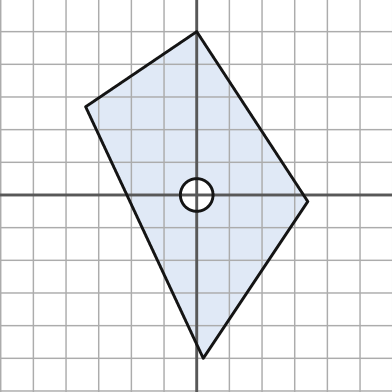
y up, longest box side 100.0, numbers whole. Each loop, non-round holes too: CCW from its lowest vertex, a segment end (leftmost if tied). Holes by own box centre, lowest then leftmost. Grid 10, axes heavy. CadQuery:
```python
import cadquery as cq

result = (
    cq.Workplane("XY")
    .moveTo(2.0, -50.0)
    .lineTo(34.0, -2.0)
    .lineTo(0.0, 50.0)
    .lineTo(-34.0, 27.0)
    .close()
    .moveTo(0.0, 0.0)
    .circle(5.0)
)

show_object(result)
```